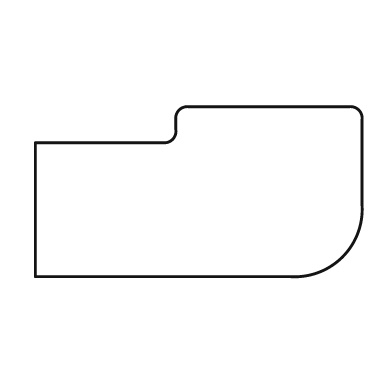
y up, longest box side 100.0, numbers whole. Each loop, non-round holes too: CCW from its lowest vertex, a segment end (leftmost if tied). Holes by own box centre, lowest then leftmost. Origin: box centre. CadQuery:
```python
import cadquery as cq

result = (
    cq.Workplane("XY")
    .moveTo(-50.0, -26.0)
    .lineTo(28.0, -26.0)
    .threePointArc((44.0, -20.0), (50.0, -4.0))
    .lineTo(50.0, 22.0)
    .threePointArc((49.0, 25.0), (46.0, 26.0))
    .lineTo(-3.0, 26.0)
    .threePointArc((-6.0, 25.0), (-7.0, 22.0))
    .lineTo(-7.0, 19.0)
    .threePointArc((-8.0, 16.0), (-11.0, 15.0))
    .lineTo(-50.0, 15.0)
    .close()
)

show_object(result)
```